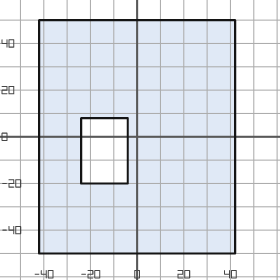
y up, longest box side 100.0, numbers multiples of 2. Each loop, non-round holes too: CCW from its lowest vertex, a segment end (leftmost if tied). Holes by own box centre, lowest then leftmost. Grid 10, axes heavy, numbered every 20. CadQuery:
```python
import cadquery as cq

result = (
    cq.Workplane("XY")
    .moveTo(-42.0, -50.0)
    .lineTo(42.0, -50.0)
    .lineTo(42.0, 50.0)
    .lineTo(-42.0, 50.0)
    .close()
    .moveTo(-24.0, -20.0)
    .lineTo(-4.0, -20.0)
    .lineTo(-4.0, 8.0)
    .lineTo(-24.0, 8.0)
    .close()
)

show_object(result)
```